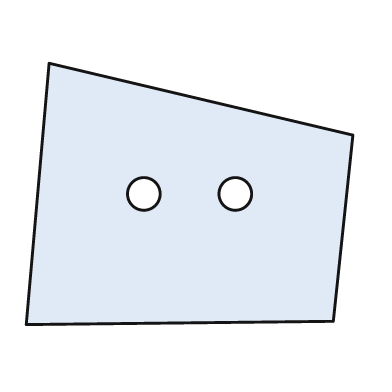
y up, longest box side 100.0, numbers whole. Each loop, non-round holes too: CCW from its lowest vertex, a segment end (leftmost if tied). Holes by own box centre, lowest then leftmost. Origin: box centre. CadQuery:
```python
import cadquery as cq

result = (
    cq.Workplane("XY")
    .moveTo(-50.0, -40.0)
    .lineTo(44.0, -39.0)
    .lineTo(50.0, 18.0)
    .lineTo(-43.0, 40.0)
    .close()
    .moveTo(-14.0, 0.0)
    .circle(5.0)
    .moveTo(14.0, 0.0)
    .circle(5.0)
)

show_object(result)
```